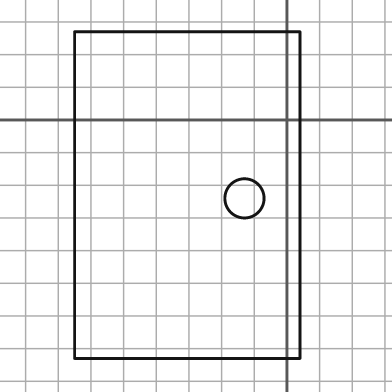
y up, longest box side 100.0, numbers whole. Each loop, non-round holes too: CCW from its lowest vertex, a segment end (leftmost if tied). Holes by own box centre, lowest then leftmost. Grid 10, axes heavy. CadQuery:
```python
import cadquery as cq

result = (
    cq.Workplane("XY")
    .moveTo(-65.0, -73.0)
    .lineTo(4.0, -73.0)
    .lineTo(4.0, 27.0)
    .lineTo(-65.0, 27.0)
    .close()
    .moveTo(-13.0, -24.0)
    .circle(6.0)
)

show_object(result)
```